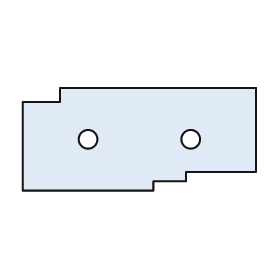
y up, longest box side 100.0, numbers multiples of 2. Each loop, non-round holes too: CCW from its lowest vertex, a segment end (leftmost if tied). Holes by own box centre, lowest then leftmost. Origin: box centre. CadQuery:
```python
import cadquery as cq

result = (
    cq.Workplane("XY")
    .moveTo(-50.0, -22.0)
    .lineTo(6.0, -22.0)
    .lineTo(6.0, -18.0)
    .lineTo(20.0, -18.0)
    .lineTo(20.0, -14.0)
    .lineTo(50.0, -14.0)
    .lineTo(50.0, 22.0)
    .lineTo(-34.0, 22.0)
    .lineTo(-34.0, 16.0)
    .lineTo(-50.0, 16.0)
    .close()
    .moveTo(-22.0, 0.0)
    .circle(4.0)
    .moveTo(22.0, 0.0)
    .circle(4.0)
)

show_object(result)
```